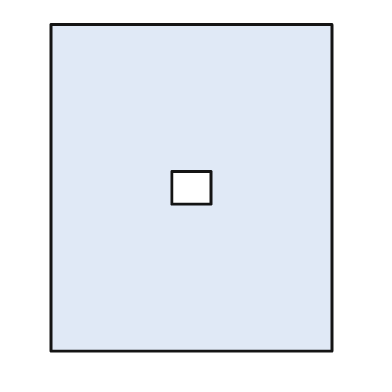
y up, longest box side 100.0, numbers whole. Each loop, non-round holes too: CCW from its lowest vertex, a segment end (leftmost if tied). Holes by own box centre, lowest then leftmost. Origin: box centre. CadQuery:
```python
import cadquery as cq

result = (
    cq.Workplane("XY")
    .moveTo(-43.0, -50.0)
    .lineTo(43.0, -50.0)
    .lineTo(43.0, 50.0)
    .lineTo(-43.0, 50.0)
    .close()
    .moveTo(-6.0, -5.0)
    .lineTo(6.0, -5.0)
    .lineTo(6.0, 5.0)
    .lineTo(-6.0, 5.0)
    .close()
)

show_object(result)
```